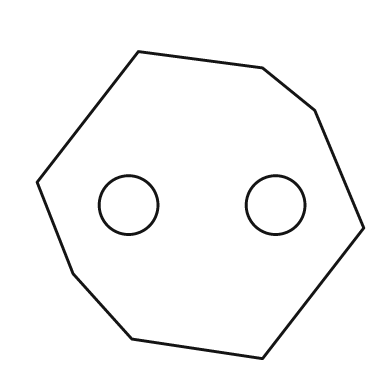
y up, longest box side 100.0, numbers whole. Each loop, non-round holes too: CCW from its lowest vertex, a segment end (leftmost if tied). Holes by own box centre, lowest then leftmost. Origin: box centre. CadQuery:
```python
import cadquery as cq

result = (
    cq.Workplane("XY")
    .moveTo(19.0, -47.0)
    .lineTo(50.0, -7.0)
    .lineTo(35.0, 29.0)
    .lineTo(19.0, 42.0)
    .lineTo(-19.0, 47.0)
    .lineTo(-50.0, 7.0)
    .lineTo(-39.0, -21.0)
    .lineTo(-21.0, -41.0)
    .close()
    .moveTo(-22.0, 0.0)
    .circle(9.0)
    .moveTo(23.0, 0.0)
    .circle(9.0)
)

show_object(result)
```